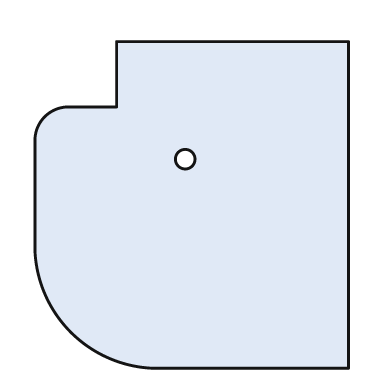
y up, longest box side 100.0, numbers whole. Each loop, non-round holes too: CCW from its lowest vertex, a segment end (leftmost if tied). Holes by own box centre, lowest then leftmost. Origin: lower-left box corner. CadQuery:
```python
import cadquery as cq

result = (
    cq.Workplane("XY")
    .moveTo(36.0, 0.0)
    .lineTo(96.0, 0.0)
    .lineTo(96.0, 100.0)
    .lineTo(25.0, 100.0)
    .lineTo(25.0, 80.0)
    .lineTo(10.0, 80.0)
    .threePointArc((3.0, 77.0), (0.0, 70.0))
    .lineTo(0.0, 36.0)
    .threePointArc((11.0, 11.0), (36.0, 0.0))
    .close()
    .moveTo(46.0, 64.0)
    .circle(3.0)
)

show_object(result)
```